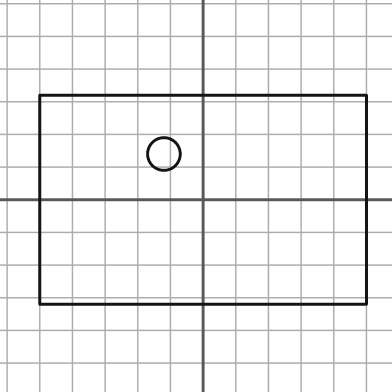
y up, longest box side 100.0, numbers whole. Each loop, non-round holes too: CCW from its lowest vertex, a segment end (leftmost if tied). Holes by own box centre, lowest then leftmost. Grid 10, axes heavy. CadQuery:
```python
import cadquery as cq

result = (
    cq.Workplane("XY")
    .moveTo(-50.0, -32.0)
    .lineTo(50.0, -32.0)
    .lineTo(50.0, 32.0)
    .lineTo(-50.0, 32.0)
    .close()
    .moveTo(-12.0, 14.0)
    .circle(5.0)
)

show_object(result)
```